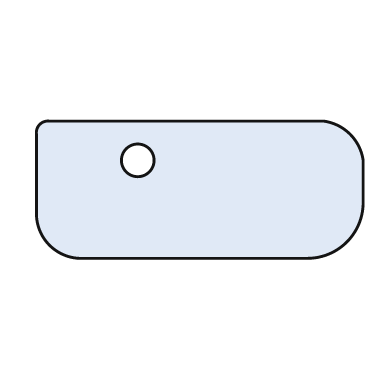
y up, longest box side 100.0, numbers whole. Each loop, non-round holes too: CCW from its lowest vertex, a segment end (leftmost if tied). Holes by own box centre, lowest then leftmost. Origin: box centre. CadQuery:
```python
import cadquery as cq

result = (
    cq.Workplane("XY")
    .moveTo(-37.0, -21.0)
    .lineTo(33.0, -21.0)
    .threePointArc((45.0, -16.0), (50.0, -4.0))
    .lineTo(50.0, 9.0)
    .threePointArc((46.0, 17.0), (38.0, 21.0))
    .lineTo(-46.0, 21.0)
    .threePointArc((-49.0, 20.0), (-50.0, 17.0))
    .lineTo(-50.0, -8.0)
    .threePointArc((-46.0, -17.0), (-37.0, -21.0))
    .close()
    .moveTo(-19.0, 9.0)
    .circle(5.0)
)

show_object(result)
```